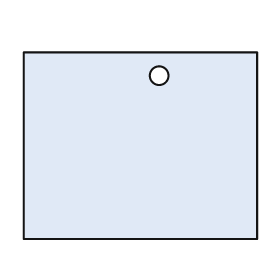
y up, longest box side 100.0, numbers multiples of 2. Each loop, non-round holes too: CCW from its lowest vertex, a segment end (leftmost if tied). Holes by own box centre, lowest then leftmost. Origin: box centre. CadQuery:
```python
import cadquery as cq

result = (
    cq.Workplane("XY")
    .moveTo(-50.0, -40.0)
    .lineTo(50.0, -40.0)
    .lineTo(50.0, 40.0)
    .lineTo(-50.0, 40.0)
    .close()
    .moveTo(8.0, 30.0)
    .circle(4.0)
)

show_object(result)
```